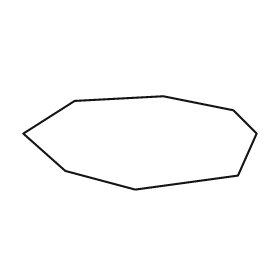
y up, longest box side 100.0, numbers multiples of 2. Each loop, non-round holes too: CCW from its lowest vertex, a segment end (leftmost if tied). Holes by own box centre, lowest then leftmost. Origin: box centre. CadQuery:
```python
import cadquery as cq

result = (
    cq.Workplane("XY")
    .moveTo(-2.0, -20.0)
    .lineTo(42.0, -14.0)
    .lineTo(50.0, 4.0)
    .lineTo(40.0, 14.0)
    .lineTo(10.0, 20.0)
    .lineTo(-28.0, 18.0)
    .lineTo(-50.0, 4.0)
    .lineTo(-32.0, -12.0)
    .close()
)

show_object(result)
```